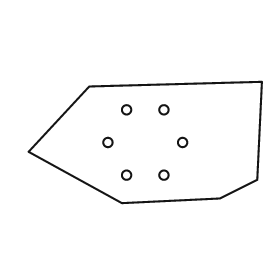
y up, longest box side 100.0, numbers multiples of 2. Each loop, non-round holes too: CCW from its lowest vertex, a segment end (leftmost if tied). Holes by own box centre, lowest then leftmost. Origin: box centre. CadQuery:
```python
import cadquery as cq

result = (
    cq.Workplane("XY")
    .moveTo(-10.0, -26.0)
    .lineTo(32.0, -24.0)
    .lineTo(48.0, -16.0)
    .lineTo(50.0, 26.0)
    .lineTo(-24.0, 24.0)
    .lineTo(-50.0, -4.0)
    .close()
    .moveTo(-8.0, -14.0)
    .circle(2.0)
    .moveTo(8.0, -14.0)
    .circle(2.0)
    .moveTo(-16.0, 0.0)
    .circle(2.0)
    .moveTo(16.0, 0.0)
    .circle(2.0)
    .moveTo(-8.0, 14.0)
    .circle(2.0)
    .moveTo(8.0, 14.0)
    .circle(2.0)
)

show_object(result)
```